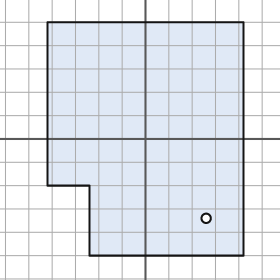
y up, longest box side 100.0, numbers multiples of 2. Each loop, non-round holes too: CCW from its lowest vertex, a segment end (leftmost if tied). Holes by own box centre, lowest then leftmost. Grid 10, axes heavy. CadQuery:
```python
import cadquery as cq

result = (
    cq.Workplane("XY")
    .moveTo(-24.0, -50.0)
    .lineTo(42.0, -50.0)
    .lineTo(42.0, 50.0)
    .lineTo(-42.0, 50.0)
    .lineTo(-42.0, -20.0)
    .lineTo(-24.0, -20.0)
    .close()
    .moveTo(26.0, -34.0)
    .circle(2.0)
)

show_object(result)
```